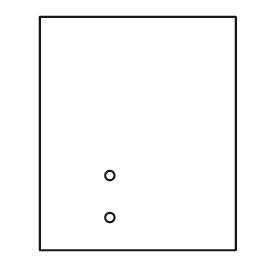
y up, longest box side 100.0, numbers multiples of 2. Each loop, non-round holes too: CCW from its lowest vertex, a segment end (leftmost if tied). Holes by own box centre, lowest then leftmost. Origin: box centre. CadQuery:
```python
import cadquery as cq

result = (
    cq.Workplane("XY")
    .moveTo(-42.0, -50.0)
    .lineTo(42.0, -50.0)
    .lineTo(42.0, 50.0)
    .lineTo(-42.0, 50.0)
    .close()
    .moveTo(-12.0, -36.0)
    .circle(2.0)
    .moveTo(-12.0, -18.0)
    .circle(2.0)
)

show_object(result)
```